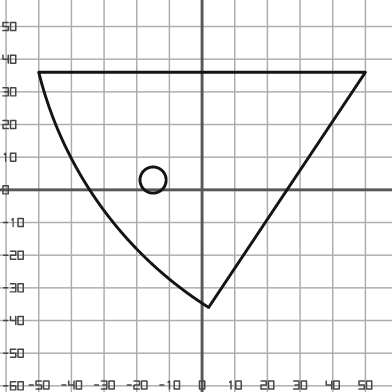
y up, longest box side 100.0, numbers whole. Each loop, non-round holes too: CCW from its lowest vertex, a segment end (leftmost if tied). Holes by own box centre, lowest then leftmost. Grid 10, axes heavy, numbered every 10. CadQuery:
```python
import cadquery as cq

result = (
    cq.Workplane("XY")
    .moveTo(2.0, -36.0)
    .lineTo(50.0, 36.0)
    .lineTo(-50.0, 36.0)
    .threePointArc((-31.0, -5.0), (2.0, -36.0))
    .close()
    .moveTo(-15.0, 3.0)
    .circle(4.0)
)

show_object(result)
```